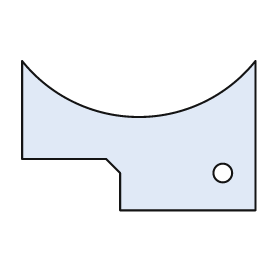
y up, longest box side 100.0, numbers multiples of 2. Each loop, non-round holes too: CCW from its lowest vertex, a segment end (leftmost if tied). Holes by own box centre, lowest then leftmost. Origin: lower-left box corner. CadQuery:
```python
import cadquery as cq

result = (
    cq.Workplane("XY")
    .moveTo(42.0, 0.0)
    .lineTo(100.0, 0.0)
    .lineTo(100.0, 64.0)
    .threePointArc((50.0, 40.0), (0.0, 64.0))
    .lineTo(0.0, 22.0)
    .lineTo(36.0, 22.0)
    .lineTo(42.0, 16.0)
    .close()
    .moveTo(86.0, 16.0)
    .circle(4.0)
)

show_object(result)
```